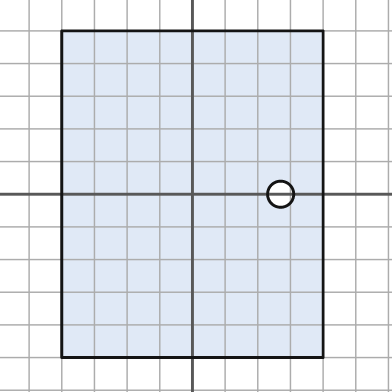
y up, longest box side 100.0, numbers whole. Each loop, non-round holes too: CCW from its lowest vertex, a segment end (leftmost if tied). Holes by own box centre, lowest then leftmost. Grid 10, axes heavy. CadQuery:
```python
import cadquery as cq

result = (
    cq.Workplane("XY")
    .moveTo(-40.0, -50.0)
    .lineTo(40.0, -50.0)
    .lineTo(40.0, 50.0)
    .lineTo(-40.0, 50.0)
    .close()
    .moveTo(27.0, 0.0)
    .circle(4.0)
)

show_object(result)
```